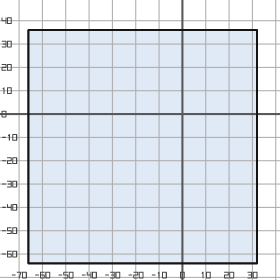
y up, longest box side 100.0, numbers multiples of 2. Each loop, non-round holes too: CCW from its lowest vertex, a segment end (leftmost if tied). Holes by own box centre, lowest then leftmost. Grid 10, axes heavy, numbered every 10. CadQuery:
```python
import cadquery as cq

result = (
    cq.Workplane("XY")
    .moveTo(-66.0, -64.0)
    .lineTo(32.0, -64.0)
    .lineTo(32.0, 36.0)
    .lineTo(-66.0, 36.0)
    .close()
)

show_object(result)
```